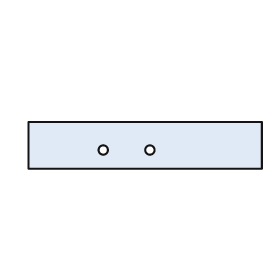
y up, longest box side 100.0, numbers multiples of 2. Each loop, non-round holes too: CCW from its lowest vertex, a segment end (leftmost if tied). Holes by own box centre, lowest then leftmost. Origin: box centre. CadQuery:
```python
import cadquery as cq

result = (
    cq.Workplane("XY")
    .moveTo(-50.0, -10.0)
    .lineTo(50.0, -10.0)
    .lineTo(50.0, 10.0)
    .lineTo(-50.0, 10.0)
    .close()
    .moveTo(-18.0, -2.0)
    .circle(2.0)
    .moveTo(2.0, -2.0)
    .circle(2.0)
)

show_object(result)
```